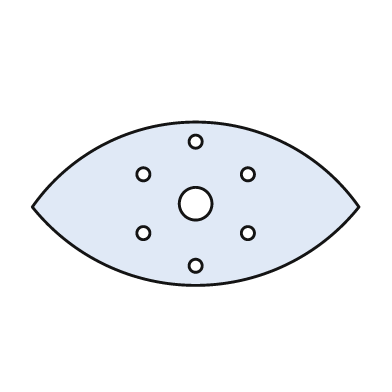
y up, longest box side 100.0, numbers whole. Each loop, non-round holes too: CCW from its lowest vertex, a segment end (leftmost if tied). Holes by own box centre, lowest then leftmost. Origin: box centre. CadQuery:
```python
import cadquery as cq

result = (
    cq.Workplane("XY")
    .moveTo(-50.0, -1.0)
    .threePointArc((0.0, -25.0), (50.0, -1.0))
    .threePointArc((0.0, 25.0), (-50.0, -1.0))
    .close()
    .moveTo(0.0, -19.0)
    .circle(2.0)
    .moveTo(-16.0, -9.0)
    .circle(2.0)
    .moveTo(16.0, -9.0)
    .circle(2.0)
    .moveTo(0.0, 0.0)
    .circle(5.0)
    .moveTo(-16.0, 9.0)
    .circle(2.0)
    .moveTo(16.0, 9.0)
    .circle(2.0)
    .moveTo(0.0, 19.0)
    .circle(2.0)
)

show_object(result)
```